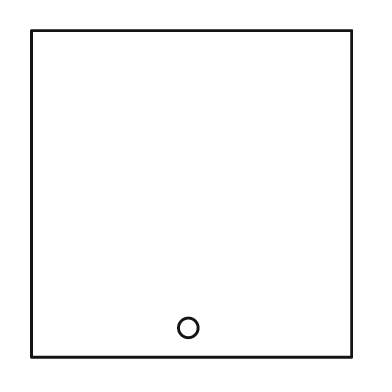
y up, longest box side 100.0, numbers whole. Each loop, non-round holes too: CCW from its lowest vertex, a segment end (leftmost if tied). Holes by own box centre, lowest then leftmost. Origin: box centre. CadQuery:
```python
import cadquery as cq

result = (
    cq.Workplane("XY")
    .moveTo(-49.0, -50.0)
    .lineTo(49.0, -50.0)
    .lineTo(49.0, 50.0)
    .lineTo(-49.0, 50.0)
    .close()
    .moveTo(-1.0, -41.0)
    .circle(3.0)
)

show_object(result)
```